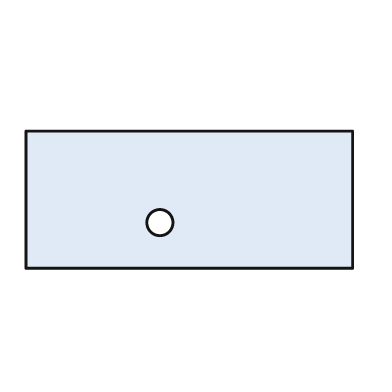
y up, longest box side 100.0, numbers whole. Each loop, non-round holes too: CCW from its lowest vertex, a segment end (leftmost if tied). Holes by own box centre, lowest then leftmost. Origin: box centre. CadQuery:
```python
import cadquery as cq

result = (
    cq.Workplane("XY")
    .moveTo(-50.0, -21.0)
    .lineTo(50.0, -21.0)
    .lineTo(50.0, 21.0)
    .lineTo(-50.0, 21.0)
    .close()
    .moveTo(-9.0, -7.0)
    .circle(4.0)
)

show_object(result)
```